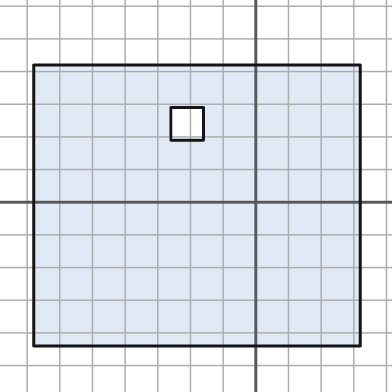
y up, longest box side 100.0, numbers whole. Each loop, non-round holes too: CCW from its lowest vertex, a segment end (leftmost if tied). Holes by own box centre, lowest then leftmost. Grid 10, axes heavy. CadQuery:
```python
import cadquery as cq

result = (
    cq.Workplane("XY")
    .moveTo(-68.0, -44.0)
    .lineTo(32.0, -44.0)
    .lineTo(32.0, 42.0)
    .lineTo(-68.0, 42.0)
    .close()
    .moveTo(-26.0, 19.0)
    .lineTo(-16.0, 19.0)
    .lineTo(-16.0, 29.0)
    .lineTo(-26.0, 29.0)
    .close()
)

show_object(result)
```